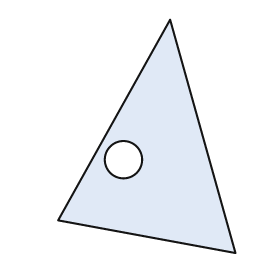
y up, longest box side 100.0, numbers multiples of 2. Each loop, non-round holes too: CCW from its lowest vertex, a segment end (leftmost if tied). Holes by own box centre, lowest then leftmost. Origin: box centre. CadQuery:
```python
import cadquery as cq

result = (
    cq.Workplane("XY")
    .moveTo(38.0, -50.0)
    .lineTo(10.0, 50.0)
    .lineTo(-38.0, -36.0)
    .close()
    .moveTo(-10.0, -10.0)
    .circle(8.0)
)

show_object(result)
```